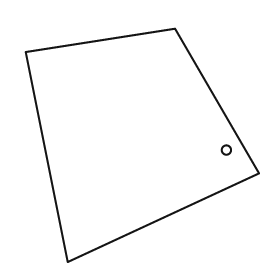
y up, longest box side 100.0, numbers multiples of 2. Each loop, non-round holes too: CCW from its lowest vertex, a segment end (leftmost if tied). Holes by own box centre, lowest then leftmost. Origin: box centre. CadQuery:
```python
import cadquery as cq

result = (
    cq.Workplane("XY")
    .moveTo(-32.0, -50.0)
    .lineTo(50.0, -12.0)
    .lineTo(14.0, 50.0)
    .lineTo(-50.0, 40.0)
    .close()
    .moveTo(36.0, -2.0)
    .circle(2.0)
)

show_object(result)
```